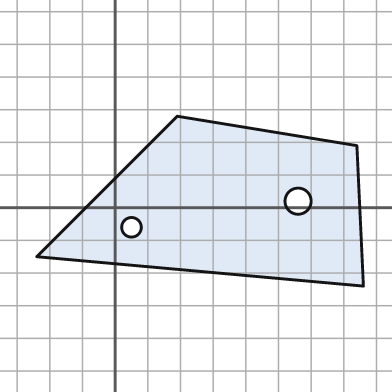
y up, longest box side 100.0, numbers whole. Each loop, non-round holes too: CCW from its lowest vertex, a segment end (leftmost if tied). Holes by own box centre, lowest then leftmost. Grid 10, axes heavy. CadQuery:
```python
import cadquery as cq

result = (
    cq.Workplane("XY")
    .moveTo(76.0, -24.0)
    .lineTo(74.0, 19.0)
    .lineTo(19.0, 28.0)
    .lineTo(-24.0, -15.0)
    .close()
    .moveTo(5.0, -6.0)
    .circle(3.0)
    .moveTo(56.0, 2.0)
    .circle(4.0)
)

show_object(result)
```